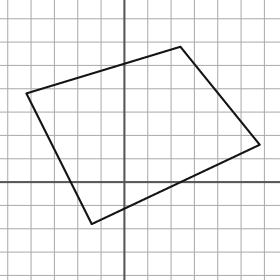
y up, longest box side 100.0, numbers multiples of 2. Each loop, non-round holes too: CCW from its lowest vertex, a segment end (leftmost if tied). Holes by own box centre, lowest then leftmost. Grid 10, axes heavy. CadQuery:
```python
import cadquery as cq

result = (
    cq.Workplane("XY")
    .moveTo(-14.0, -18.0)
    .lineTo(58.0, 16.0)
    .lineTo(24.0, 58.0)
    .lineTo(-42.0, 38.0)
    .close()
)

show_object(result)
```